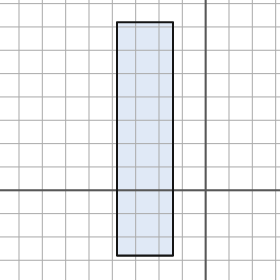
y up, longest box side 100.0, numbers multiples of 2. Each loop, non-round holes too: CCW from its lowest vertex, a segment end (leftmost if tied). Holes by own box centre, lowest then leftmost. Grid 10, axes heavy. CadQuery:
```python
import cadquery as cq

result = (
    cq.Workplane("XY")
    .moveTo(-38.0, -28.0)
    .lineTo(-14.0, -28.0)
    .lineTo(-14.0, 72.0)
    .lineTo(-38.0, 72.0)
    .close()
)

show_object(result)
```